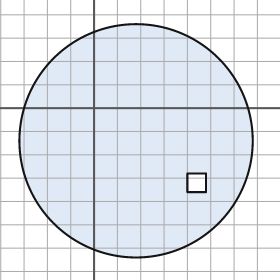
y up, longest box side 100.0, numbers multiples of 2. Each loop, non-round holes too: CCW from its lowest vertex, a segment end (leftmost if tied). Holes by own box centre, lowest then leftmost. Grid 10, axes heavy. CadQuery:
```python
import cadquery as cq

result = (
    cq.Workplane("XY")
    .moveTo(18.0, -14.0)
    .circle(50.0)
    .moveTo(40.0, -36.0)
    .lineTo(48.0, -36.0)
    .lineTo(48.0, -28.0)
    .lineTo(40.0, -28.0)
    .close()
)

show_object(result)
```